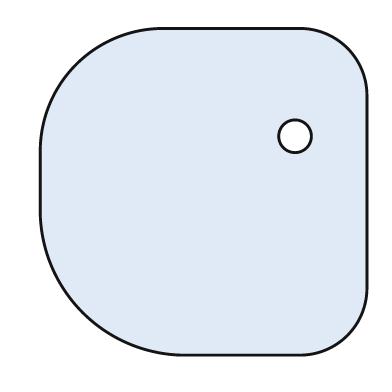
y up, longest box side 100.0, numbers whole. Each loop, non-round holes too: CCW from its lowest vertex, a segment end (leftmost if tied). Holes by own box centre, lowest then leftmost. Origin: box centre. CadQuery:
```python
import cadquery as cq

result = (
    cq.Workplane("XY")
    .moveTo(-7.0, -50.0)
    .lineTo(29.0, -50.0)
    .threePointArc((44.0, -44.0), (50.0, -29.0))
    .lineTo(50.0, 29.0)
    .threePointArc((44.0, 44.0), (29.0, 50.0))
    .lineTo(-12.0, 50.0)
    .threePointArc((-39.0, 39.0), (-50.0, 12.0))
    .lineTo(-50.0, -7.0)
    .threePointArc((-37.0, -37.0), (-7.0, -50.0))
    .close()
    .moveTo(28.0, 17.0)
    .circle(5.0)
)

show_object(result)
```